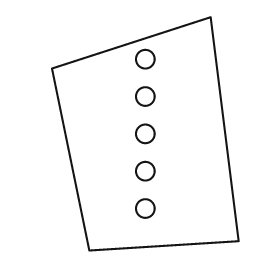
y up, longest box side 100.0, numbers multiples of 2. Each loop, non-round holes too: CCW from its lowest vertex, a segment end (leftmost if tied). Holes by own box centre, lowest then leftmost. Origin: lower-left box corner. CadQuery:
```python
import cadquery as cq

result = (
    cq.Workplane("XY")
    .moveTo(16.0, 0.0)
    .lineTo(80.0, 4.0)
    .lineTo(68.0, 100.0)
    .lineTo(0.0, 78.0)
    .close()
    .moveTo(40.0, 18.0)
    .circle(4.0)
    .moveTo(40.0, 34.0)
    .circle(4.0)
    .moveTo(40.0, 50.0)
    .circle(4.0)
    .moveTo(40.0, 66.0)
    .circle(4.0)
    .moveTo(40.0, 82.0)
    .circle(4.0)
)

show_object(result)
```